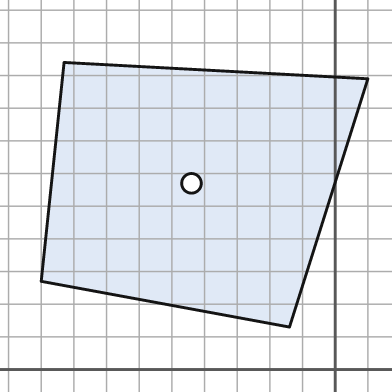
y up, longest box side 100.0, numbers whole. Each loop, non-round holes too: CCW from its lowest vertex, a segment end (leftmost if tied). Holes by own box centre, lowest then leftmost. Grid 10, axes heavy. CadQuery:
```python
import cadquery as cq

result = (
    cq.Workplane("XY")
    .moveTo(-14.0, 13.0)
    .lineTo(10.0, 89.0)
    .lineTo(-83.0, 94.0)
    .lineTo(-90.0, 27.0)
    .close()
    .moveTo(-44.0, 57.0)
    .circle(3.0)
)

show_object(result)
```